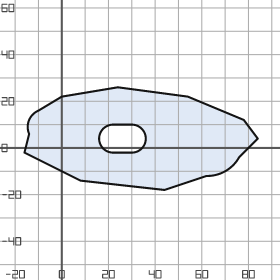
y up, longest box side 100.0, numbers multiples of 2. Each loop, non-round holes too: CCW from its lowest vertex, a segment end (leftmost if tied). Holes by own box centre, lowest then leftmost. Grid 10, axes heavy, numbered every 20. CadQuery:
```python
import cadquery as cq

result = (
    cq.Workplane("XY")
    .moveTo(44.0, -18.0)
    .lineTo(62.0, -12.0)
    .threePointArc((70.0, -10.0), (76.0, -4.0))
    .lineTo(84.0, 4.0)
    .lineTo(78.0, 12.0)
    .lineTo(54.0, 22.0)
    .lineTo(24.0, 26.0)
    .lineTo(0.0, 22.0)
    .lineTo(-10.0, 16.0)
    .threePointArc((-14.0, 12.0), (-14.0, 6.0))
    .lineTo(-16.0, -2.0)
    .lineTo(8.0, -14.0)
    .close()
    .moveTo(22.0, -2.0)
    .lineTo(30.0, -2.0)
    .threePointArc((36.0, 4.0), (30.0, 10.0))
    .lineTo(22.0, 10.0)
    .threePointArc((16.0, 4.0), (22.0, -2.0))
    .close()
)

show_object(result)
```